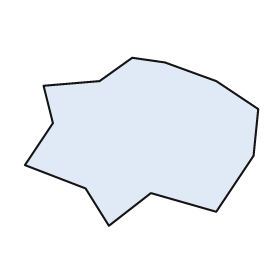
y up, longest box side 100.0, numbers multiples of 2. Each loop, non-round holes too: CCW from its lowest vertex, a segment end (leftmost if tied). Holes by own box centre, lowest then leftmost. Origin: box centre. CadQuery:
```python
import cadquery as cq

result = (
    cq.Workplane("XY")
    .moveTo(-14.0, -36.0)
    .lineTo(4.0, -22.0)
    .lineTo(32.0, -30.0)
    .lineTo(48.0, -6.0)
    .lineTo(50.0, 14.0)
    .lineTo(32.0, 26.0)
    .lineTo(10.0, 34.0)
    .lineTo(-4.0, 36.0)
    .lineTo(-18.0, 26.0)
    .lineTo(-42.0, 24.0)
    .lineTo(-38.0, 8.0)
    .lineTo(-50.0, -10.0)
    .lineTo(-24.0, -20.0)
    .close()
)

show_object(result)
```